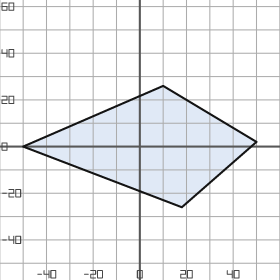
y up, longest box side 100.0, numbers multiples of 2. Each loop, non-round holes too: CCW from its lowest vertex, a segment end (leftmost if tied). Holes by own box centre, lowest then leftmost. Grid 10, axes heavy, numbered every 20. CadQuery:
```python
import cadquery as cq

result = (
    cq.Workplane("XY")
    .moveTo(18.0, -26.0)
    .lineTo(50.0, 2.0)
    .lineTo(10.0, 26.0)
    .lineTo(-50.0, 0.0)
    .close()
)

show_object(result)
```